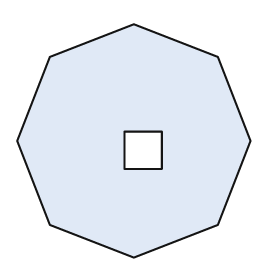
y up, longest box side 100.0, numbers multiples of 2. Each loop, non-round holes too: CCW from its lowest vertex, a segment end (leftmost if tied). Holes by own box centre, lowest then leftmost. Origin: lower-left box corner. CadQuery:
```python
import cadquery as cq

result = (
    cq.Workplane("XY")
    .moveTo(50.0, 0.0)
    .lineTo(86.0, 14.0)
    .lineTo(100.0, 50.0)
    .lineTo(86.0, 86.0)
    .lineTo(50.0, 100.0)
    .lineTo(14.0, 86.0)
    .lineTo(0.0, 50.0)
    .lineTo(14.0, 14.0)
    .close()
    .moveTo(46.0, 38.0)
    .lineTo(62.0, 38.0)
    .lineTo(62.0, 54.0)
    .lineTo(46.0, 54.0)
    .close()
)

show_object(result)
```